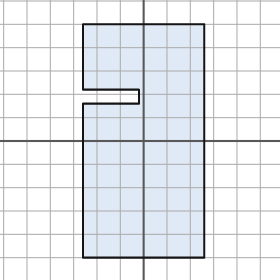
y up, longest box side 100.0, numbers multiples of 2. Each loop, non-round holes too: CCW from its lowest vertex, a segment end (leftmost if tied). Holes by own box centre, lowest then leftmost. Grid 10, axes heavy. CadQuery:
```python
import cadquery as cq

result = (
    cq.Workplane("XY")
    .moveTo(-26.0, -50.0)
    .lineTo(26.0, -50.0)
    .lineTo(26.0, 50.0)
    .lineTo(-26.0, 50.0)
    .lineTo(-26.0, 22.0)
    .lineTo(-2.0, 22.0)
    .lineTo(-2.0, 16.0)
    .lineTo(-26.0, 16.0)
    .close()
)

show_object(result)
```